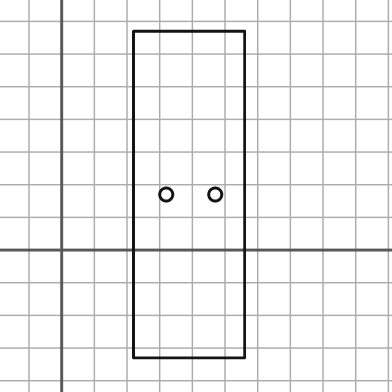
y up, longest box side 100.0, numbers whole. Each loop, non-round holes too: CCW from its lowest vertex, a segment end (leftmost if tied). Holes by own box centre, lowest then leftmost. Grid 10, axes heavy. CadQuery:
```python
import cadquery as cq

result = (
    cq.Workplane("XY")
    .moveTo(22.0, -33.0)
    .lineTo(56.0, -33.0)
    .lineTo(56.0, 67.0)
    .lineTo(22.0, 67.0)
    .close()
    .moveTo(32.0, 17.0)
    .circle(2.0)
    .moveTo(47.0, 17.0)
    .circle(2.0)
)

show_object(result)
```